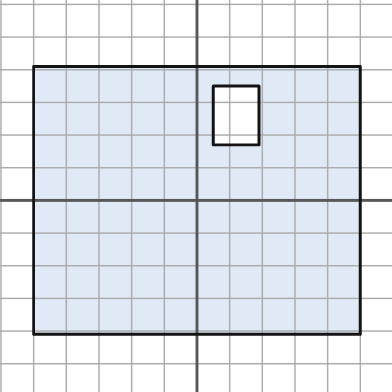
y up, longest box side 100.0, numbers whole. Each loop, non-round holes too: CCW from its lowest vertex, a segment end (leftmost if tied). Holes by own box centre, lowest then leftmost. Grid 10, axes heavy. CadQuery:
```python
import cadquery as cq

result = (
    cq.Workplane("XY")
    .moveTo(-50.0, -41.0)
    .lineTo(50.0, -41.0)
    .lineTo(50.0, 41.0)
    .lineTo(-50.0, 41.0)
    .close()
    .moveTo(5.0, 17.0)
    .lineTo(19.0, 17.0)
    .lineTo(19.0, 35.0)
    .lineTo(5.0, 35.0)
    .close()
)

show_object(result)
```